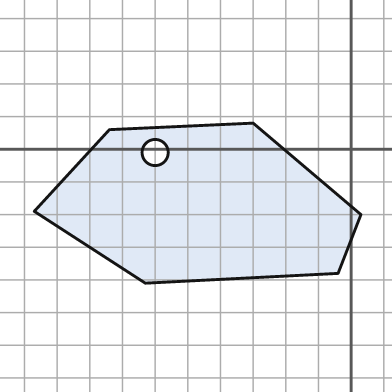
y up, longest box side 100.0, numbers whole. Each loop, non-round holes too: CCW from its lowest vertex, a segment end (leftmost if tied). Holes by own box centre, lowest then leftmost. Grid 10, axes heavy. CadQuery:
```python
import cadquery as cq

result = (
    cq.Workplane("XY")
    .moveTo(-63.0, -41.0)
    .lineTo(-4.0, -38.0)
    .lineTo(3.0, -20.0)
    .lineTo(-30.0, 8.0)
    .lineTo(-74.0, 6.0)
    .lineTo(-97.0, -19.0)
    .close()
    .moveTo(-60.0, -1.0)
    .circle(4.0)
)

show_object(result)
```